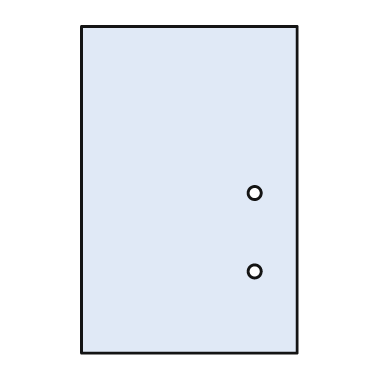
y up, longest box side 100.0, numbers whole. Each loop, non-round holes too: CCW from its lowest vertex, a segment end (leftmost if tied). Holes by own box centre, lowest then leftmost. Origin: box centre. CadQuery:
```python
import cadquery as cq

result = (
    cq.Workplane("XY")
    .moveTo(-33.0, -50.0)
    .lineTo(33.0, -50.0)
    .lineTo(33.0, 50.0)
    .lineTo(-33.0, 50.0)
    .close()
    .moveTo(20.0, -25.0)
    .circle(2.0)
    .moveTo(20.0, -1.0)
    .circle(2.0)
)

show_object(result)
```